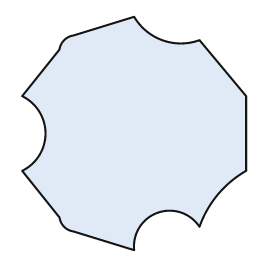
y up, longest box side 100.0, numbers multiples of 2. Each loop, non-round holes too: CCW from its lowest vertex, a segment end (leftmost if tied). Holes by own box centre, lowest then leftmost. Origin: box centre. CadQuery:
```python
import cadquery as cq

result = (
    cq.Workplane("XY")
    .moveTo(0.0, -50.0)
    .threePointArc((10.0, -34.0), (28.0, -40.0))
    .threePointArc((36.0, -26.0), (48.0, -16.0))
    .lineTo(48.0, 16.0)
    .lineTo(28.0, 40.0)
    .threePointArc((12.0, 40.0), (0.0, 50.0))
    .lineTo(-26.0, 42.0)
    .threePointArc((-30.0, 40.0), (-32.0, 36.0))
    .lineTo(-48.0, 16.0)
    .threePointArc((-38.0, 0.0), (-48.0, -16.0))
    .lineTo(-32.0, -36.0)
    .threePointArc((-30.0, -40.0), (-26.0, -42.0))
    .close()
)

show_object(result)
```